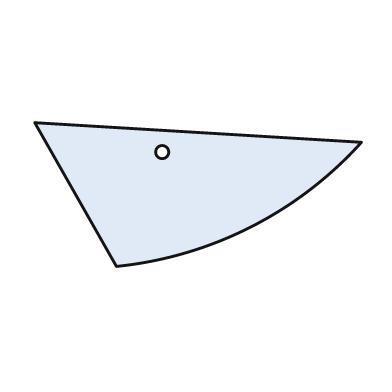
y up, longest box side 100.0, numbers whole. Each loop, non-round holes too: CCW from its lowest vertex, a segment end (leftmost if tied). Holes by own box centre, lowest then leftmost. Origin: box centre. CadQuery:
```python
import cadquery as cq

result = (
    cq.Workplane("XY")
    .moveTo(-25.0, -22.0)
    .threePointArc((16.0, -10.0), (50.0, 16.0))
    .lineTo(-50.0, 22.0)
    .close()
    .moveTo(-11.0, 13.0)
    .circle(2.0)
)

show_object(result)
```